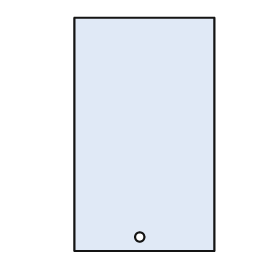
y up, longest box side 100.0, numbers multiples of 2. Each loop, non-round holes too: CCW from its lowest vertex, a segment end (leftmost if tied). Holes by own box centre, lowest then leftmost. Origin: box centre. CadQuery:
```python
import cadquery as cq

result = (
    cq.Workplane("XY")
    .moveTo(-30.0, -50.0)
    .lineTo(30.0, -50.0)
    .lineTo(30.0, 50.0)
    .lineTo(-30.0, 50.0)
    .close()
    .moveTo(-2.0, -44.0)
    .circle(2.0)
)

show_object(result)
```